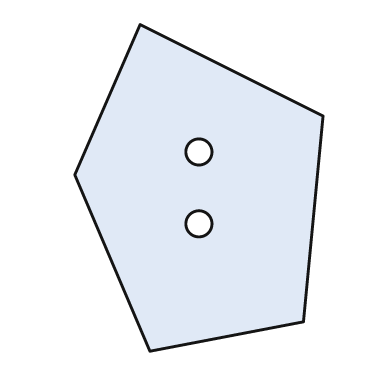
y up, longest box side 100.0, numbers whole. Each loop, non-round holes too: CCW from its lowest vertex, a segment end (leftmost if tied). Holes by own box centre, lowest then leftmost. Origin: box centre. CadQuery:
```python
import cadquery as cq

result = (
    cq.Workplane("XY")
    .moveTo(-15.0, -50.0)
    .lineTo(32.0, -41.0)
    .lineTo(38.0, 22.0)
    .lineTo(-18.0, 50.0)
    .lineTo(-38.0, 4.0)
    .close()
    .moveTo(0.0, -11.0)
    .circle(4.0)
    .moveTo(0.0, 11.0)
    .circle(4.0)
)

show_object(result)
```